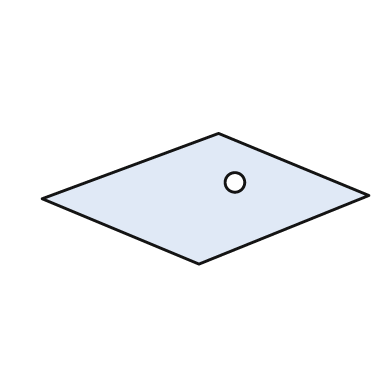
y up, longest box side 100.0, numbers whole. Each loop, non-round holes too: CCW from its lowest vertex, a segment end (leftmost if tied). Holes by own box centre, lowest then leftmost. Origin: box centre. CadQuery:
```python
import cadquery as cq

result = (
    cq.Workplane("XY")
    .moveTo(-2.0, -20.0)
    .lineTo(50.0, 1.0)
    .lineTo(4.0, 20.0)
    .lineTo(-50.0, 0.0)
    .close()
    .moveTo(9.0, 5.0)
    .circle(3.0)
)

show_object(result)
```